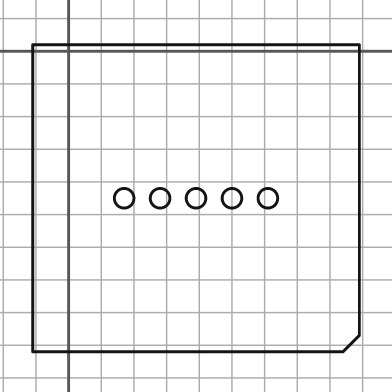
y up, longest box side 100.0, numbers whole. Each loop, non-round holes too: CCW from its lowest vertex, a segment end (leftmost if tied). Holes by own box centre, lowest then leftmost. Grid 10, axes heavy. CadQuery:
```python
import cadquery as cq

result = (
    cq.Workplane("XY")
    .moveTo(-11.0, -92.0)
    .lineTo(84.0, -92.0)
    .lineTo(89.0, -87.0)
    .lineTo(89.0, 2.0)
    .lineTo(-11.0, 2.0)
    .close()
    .moveTo(17.0, -45.0)
    .circle(3.0)
    .moveTo(28.0, -45.0)
    .circle(3.0)
    .moveTo(39.0, -45.0)
    .circle(3.0)
    .moveTo(50.0, -45.0)
    .circle(3.0)
    .moveTo(61.0, -45.0)
    .circle(3.0)
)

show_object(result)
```